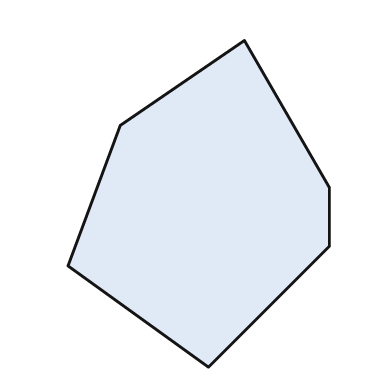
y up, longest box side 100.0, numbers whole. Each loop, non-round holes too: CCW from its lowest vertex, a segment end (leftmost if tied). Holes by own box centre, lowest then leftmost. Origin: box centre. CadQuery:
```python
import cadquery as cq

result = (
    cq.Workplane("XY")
    .moveTo(3.0, -50.0)
    .lineTo(40.0, -13.0)
    .lineTo(40.0, 5.0)
    .lineTo(14.0, 50.0)
    .lineTo(-24.0, 24.0)
    .lineTo(-40.0, -19.0)
    .close()
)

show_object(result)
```